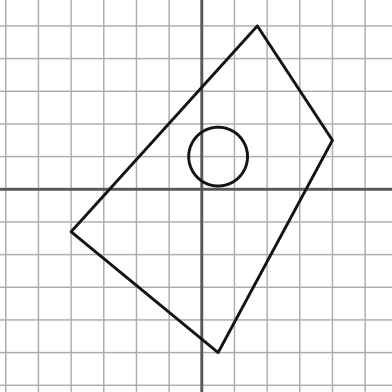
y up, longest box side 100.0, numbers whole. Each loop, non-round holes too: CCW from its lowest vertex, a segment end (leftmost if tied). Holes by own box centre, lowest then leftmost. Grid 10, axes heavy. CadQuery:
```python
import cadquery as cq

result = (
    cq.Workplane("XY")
    .moveTo(5.0, -50.0)
    .lineTo(40.0, 15.0)
    .lineTo(17.0, 50.0)
    .lineTo(-40.0, -13.0)
    .close()
    .moveTo(5.0, 10.0)
    .circle(9.0)
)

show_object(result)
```